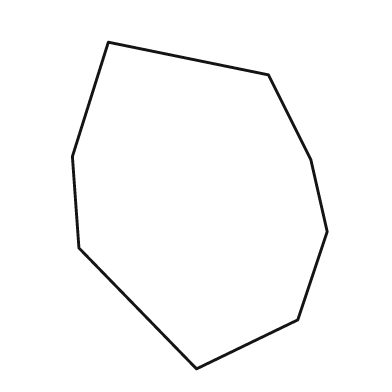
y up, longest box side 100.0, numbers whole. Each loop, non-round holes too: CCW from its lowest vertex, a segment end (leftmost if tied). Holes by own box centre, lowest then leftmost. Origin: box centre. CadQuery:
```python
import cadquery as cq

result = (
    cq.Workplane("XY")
    .moveTo(-1.0, -50.0)
    .lineTo(30.0, -35.0)
    .lineTo(39.0, -8.0)
    .lineTo(34.0, 14.0)
    .lineTo(21.0, 40.0)
    .lineTo(-28.0, 50.0)
    .lineTo(-39.0, 15.0)
    .lineTo(-37.0, -13.0)
    .close()
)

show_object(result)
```